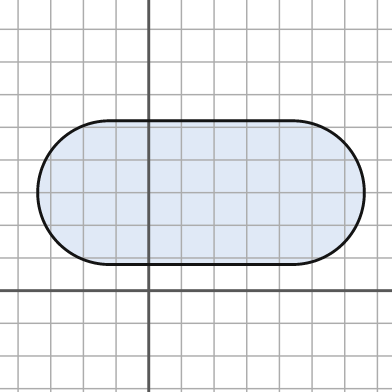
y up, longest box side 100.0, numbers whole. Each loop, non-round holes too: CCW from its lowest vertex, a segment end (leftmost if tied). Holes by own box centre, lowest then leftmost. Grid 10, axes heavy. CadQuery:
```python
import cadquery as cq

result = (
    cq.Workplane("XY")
    .moveTo(-12.0, 8.0)
    .lineTo(44.0, 8.0)
    .threePointArc((66.0, 30.0), (44.0, 52.0))
    .lineTo(-12.0, 52.0)
    .threePointArc((-34.0, 30.0), (-12.0, 8.0))
    .close()
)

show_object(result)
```